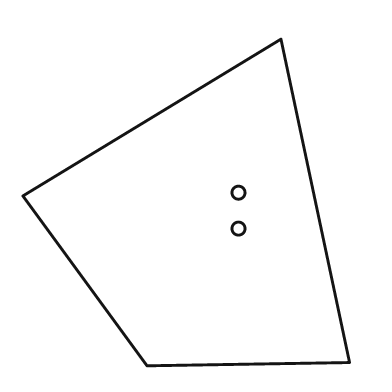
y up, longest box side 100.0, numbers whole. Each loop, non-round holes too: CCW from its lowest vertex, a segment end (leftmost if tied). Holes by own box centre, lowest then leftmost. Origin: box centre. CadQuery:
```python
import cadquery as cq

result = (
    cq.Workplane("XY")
    .moveTo(-12.0, -50.0)
    .lineTo(50.0, -49.0)
    .lineTo(29.0, 50.0)
    .lineTo(-50.0, 2.0)
    .close()
    .moveTo(16.0, -8.0)
    .circle(2.0)
    .moveTo(16.0, 3.0)
    .circle(2.0)
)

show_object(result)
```